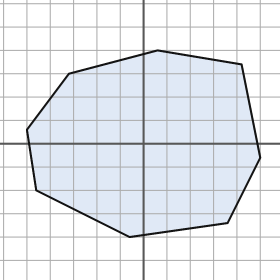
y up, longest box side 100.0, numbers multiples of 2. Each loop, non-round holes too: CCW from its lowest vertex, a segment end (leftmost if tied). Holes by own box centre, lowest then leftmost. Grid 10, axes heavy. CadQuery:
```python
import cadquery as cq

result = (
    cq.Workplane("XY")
    .moveTo(-6.0, -40.0)
    .lineTo(36.0, -34.0)
    .lineTo(50.0, -6.0)
    .lineTo(42.0, 34.0)
    .lineTo(6.0, 40.0)
    .lineTo(-32.0, 30.0)
    .lineTo(-50.0, 6.0)
    .lineTo(-46.0, -20.0)
    .close()
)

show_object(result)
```